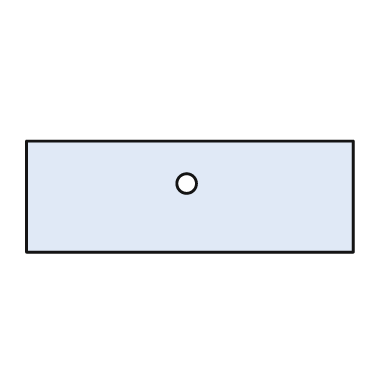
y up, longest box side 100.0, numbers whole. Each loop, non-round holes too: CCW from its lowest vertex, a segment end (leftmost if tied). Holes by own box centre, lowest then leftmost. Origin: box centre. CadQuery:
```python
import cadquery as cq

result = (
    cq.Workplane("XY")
    .moveTo(-50.0, -17.0)
    .lineTo(50.0, -17.0)
    .lineTo(50.0, 17.0)
    .lineTo(-50.0, 17.0)
    .close()
    .moveTo(-1.0, 4.0)
    .circle(3.0)
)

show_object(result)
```